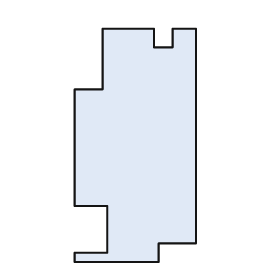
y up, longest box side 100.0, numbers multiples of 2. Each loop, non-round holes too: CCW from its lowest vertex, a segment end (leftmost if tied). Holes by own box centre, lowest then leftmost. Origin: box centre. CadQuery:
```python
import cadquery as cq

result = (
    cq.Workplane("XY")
    .moveTo(-26.0, -50.0)
    .lineTo(10.0, -50.0)
    .lineTo(10.0, -42.0)
    .lineTo(26.0, -42.0)
    .lineTo(26.0, 50.0)
    .lineTo(16.0, 50.0)
    .lineTo(16.0, 42.0)
    .lineTo(8.0, 42.0)
    .lineTo(8.0, 50.0)
    .lineTo(-14.0, 50.0)
    .lineTo(-14.0, 24.0)
    .lineTo(-26.0, 24.0)
    .lineTo(-26.0, -26.0)
    .lineTo(-12.0, -26.0)
    .lineTo(-12.0, -46.0)
    .lineTo(-26.0, -46.0)
    .close()
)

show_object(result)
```